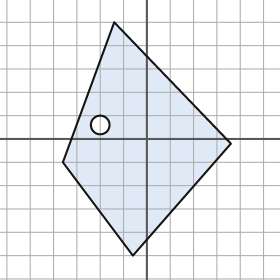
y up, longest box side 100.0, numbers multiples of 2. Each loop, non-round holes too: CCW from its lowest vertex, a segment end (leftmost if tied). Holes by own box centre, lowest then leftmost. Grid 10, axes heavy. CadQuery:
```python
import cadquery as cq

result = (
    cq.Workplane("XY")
    .moveTo(-6.0, -50.0)
    .lineTo(36.0, -2.0)
    .lineTo(-14.0, 50.0)
    .lineTo(-36.0, -10.0)
    .close()
    .moveTo(-20.0, 6.0)
    .circle(4.0)
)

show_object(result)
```